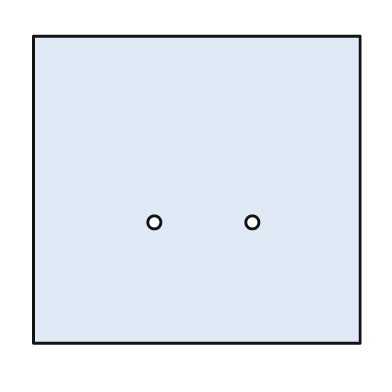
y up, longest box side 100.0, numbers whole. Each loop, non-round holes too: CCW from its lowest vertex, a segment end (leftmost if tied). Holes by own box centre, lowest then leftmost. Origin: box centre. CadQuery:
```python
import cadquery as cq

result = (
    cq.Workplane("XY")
    .moveTo(-50.0, -47.0)
    .lineTo(50.0, -47.0)
    .lineTo(50.0, 47.0)
    .lineTo(-50.0, 47.0)
    .close()
    .moveTo(-13.0, -10.0)
    .circle(2.0)
    .moveTo(17.0, -10.0)
    .circle(2.0)
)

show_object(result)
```